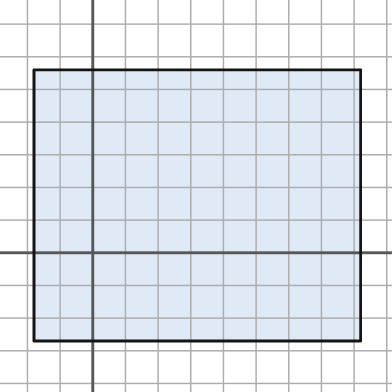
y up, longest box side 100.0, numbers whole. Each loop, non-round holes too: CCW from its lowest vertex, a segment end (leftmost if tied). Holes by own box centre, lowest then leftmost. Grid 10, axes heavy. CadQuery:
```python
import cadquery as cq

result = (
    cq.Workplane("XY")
    .moveTo(-18.0, -27.0)
    .lineTo(82.0, -27.0)
    .lineTo(82.0, 56.0)
    .lineTo(-18.0, 56.0)
    .close()
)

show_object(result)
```